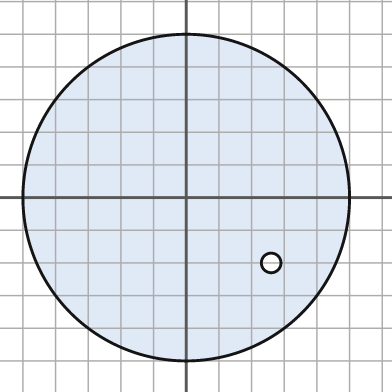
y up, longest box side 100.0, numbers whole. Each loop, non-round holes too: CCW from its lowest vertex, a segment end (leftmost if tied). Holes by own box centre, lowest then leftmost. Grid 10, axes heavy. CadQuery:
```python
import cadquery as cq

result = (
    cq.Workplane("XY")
    .moveTo(0.0, 0.0)
    .circle(50.0)
    .moveTo(26.0, -20.0)
    .circle(3.0)
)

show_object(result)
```